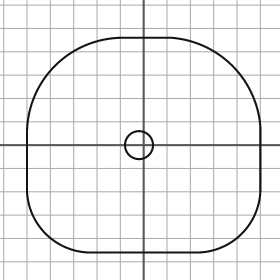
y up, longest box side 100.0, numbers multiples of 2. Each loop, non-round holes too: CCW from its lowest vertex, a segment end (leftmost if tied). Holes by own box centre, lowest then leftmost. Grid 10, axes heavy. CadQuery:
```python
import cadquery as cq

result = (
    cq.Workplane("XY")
    .moveTo(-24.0, -46.0)
    .lineTo(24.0, -46.0)
    .threePointArc((42.0, -38.0), (50.0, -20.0))
    .lineTo(50.0, 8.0)
    .threePointArc((38.0, 34.0), (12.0, 46.0))
    .lineTo(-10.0, 46.0)
    .threePointArc((-38.0, 34.0), (-50.0, 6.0))
    .lineTo(-50.0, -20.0)
    .threePointArc((-42.0, -38.0), (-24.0, -46.0))
    .close()
    .moveTo(-2.0, 0.0)
    .circle(6.0)
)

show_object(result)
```